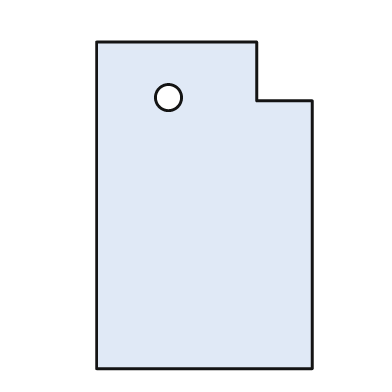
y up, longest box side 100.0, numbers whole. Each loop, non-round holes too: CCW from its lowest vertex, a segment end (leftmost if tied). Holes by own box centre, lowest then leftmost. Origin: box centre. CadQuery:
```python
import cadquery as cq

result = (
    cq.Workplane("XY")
    .moveTo(-33.0, -50.0)
    .lineTo(33.0, -50.0)
    .lineTo(33.0, 32.0)
    .lineTo(16.0, 32.0)
    .lineTo(16.0, 50.0)
    .lineTo(-33.0, 50.0)
    .close()
    .moveTo(-11.0, 33.0)
    .circle(4.0)
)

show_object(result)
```